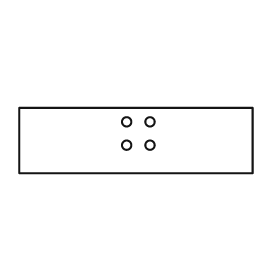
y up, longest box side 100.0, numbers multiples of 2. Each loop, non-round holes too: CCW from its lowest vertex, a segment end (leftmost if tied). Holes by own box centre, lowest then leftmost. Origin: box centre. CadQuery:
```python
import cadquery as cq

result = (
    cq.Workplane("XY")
    .moveTo(-50.0, -14.0)
    .lineTo(50.0, -14.0)
    .lineTo(50.0, 14.0)
    .lineTo(-50.0, 14.0)
    .close()
    .moveTo(-4.0, -2.0)
    .circle(2.0)
    .moveTo(6.0, -2.0)
    .circle(2.0)
    .moveTo(-4.0, 8.0)
    .circle(2.0)
    .moveTo(6.0, 8.0)
    .circle(2.0)
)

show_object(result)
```